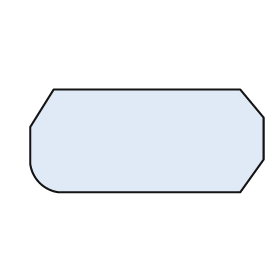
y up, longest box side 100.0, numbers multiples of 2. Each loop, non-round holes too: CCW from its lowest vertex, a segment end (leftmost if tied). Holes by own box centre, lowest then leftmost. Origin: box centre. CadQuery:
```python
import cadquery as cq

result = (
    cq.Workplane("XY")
    .moveTo(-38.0, -22.0)
    .lineTo(40.0, -22.0)
    .lineTo(50.0, -8.0)
    .lineTo(50.0, 10.0)
    .lineTo(40.0, 22.0)
    .lineTo(-40.0, 22.0)
    .lineTo(-50.0, 6.0)
    .lineTo(-50.0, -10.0)
    .threePointArc((-46.0, -18.0), (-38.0, -22.0))
    .close()
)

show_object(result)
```